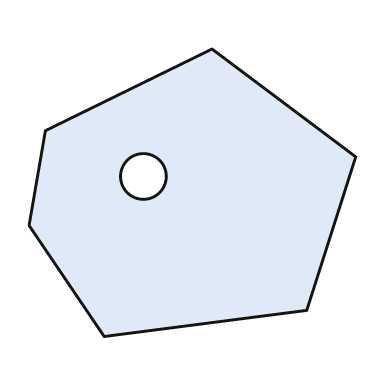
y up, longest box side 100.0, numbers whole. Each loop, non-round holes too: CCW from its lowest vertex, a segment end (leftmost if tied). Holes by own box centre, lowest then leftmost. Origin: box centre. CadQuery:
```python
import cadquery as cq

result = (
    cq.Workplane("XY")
    .moveTo(-27.0, -44.0)
    .lineTo(35.0, -36.0)
    .lineTo(50.0, 11.0)
    .lineTo(6.0, 44.0)
    .lineTo(-45.0, 19.0)
    .lineTo(-50.0, -10.0)
    .close()
    .moveTo(-15.0, 5.0)
    .circle(7.0)
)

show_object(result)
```